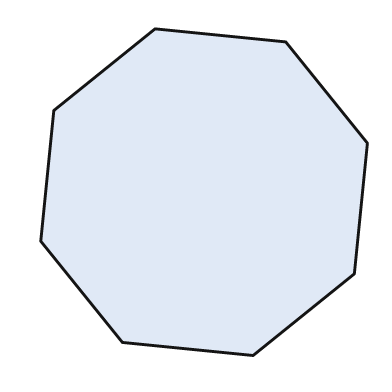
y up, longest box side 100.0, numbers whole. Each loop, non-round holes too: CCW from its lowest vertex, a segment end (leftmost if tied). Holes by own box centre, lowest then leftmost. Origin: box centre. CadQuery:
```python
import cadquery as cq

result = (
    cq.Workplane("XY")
    .moveTo(15.0, -50.0)
    .lineTo(46.0, -25.0)
    .lineTo(50.0, 15.0)
    .lineTo(25.0, 46.0)
    .lineTo(-15.0, 50.0)
    .lineTo(-46.0, 25.0)
    .lineTo(-50.0, -15.0)
    .lineTo(-25.0, -46.0)
    .close()
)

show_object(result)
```